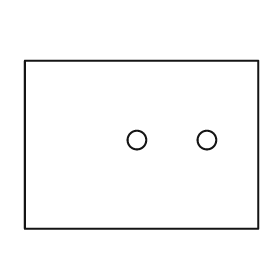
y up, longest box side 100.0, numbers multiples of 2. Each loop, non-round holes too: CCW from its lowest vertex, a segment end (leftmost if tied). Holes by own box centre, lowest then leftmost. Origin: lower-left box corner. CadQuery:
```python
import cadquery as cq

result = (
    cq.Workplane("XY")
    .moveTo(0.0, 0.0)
    .lineTo(100.0, 0.0)
    .lineTo(100.0, 72.0)
    .lineTo(0.0, 72.0)
    .close()
    .moveTo(48.0, 38.0)
    .circle(4.0)
    .moveTo(78.0, 38.0)
    .circle(4.0)
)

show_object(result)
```